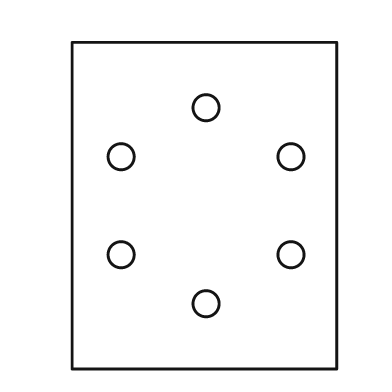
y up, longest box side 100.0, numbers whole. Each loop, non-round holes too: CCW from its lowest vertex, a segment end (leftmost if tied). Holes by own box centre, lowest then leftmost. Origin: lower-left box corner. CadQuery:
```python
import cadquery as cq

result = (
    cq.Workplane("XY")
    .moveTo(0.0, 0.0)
    .lineTo(81.0, 0.0)
    .lineTo(81.0, 100.0)
    .lineTo(0.0, 100.0)
    .close()
    .moveTo(41.0, 20.0)
    .circle(4.0)
    .moveTo(15.0, 35.0)
    .circle(4.0)
    .moveTo(67.0, 35.0)
    .circle(4.0)
    .moveTo(15.0, 65.0)
    .circle(4.0)
    .moveTo(67.0, 65.0)
    .circle(4.0)
    .moveTo(41.0, 80.0)
    .circle(4.0)
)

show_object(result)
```